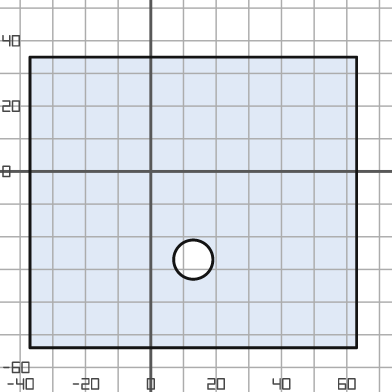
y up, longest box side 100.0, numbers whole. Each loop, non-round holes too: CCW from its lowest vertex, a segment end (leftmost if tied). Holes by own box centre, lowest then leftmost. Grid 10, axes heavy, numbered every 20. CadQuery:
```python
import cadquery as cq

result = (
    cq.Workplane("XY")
    .moveTo(-37.0, -54.0)
    .lineTo(63.0, -54.0)
    .lineTo(63.0, 35.0)
    .lineTo(-37.0, 35.0)
    .close()
    .moveTo(13.0, -27.0)
    .circle(6.0)
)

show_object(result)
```